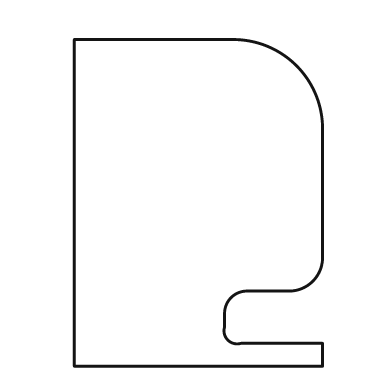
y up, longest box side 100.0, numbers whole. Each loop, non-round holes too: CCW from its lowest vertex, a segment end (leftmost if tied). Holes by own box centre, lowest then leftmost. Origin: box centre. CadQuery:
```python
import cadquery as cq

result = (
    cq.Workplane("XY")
    .moveTo(-38.0, -50.0)
    .lineTo(38.0, -50.0)
    .lineTo(38.0, -43.0)
    .lineTo(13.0, -43.0)
    .threePointArc((9.0, -42.0), (8.0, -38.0))
    .lineTo(8.0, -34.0)
    .threePointArc((10.0, -29.0), (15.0, -27.0))
    .lineTo(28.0, -27.0)
    .threePointArc((35.0, -24.0), (38.0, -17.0))
    .lineTo(38.0, 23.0)
    .threePointArc((30.0, 42.0), (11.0, 50.0))
    .lineTo(-38.0, 50.0)
    .close()
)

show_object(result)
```